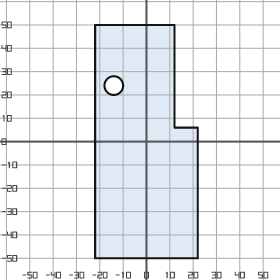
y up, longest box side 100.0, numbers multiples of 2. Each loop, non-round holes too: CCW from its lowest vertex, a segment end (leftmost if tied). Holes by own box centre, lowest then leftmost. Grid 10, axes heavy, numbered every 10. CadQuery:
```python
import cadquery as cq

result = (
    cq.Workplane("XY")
    .moveTo(-22.0, -50.0)
    .lineTo(22.0, -50.0)
    .lineTo(22.0, 6.0)
    .lineTo(12.0, 6.0)
    .lineTo(12.0, 50.0)
    .lineTo(-22.0, 50.0)
    .close()
    .moveTo(-14.0, 24.0)
    .circle(4.0)
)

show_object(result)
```